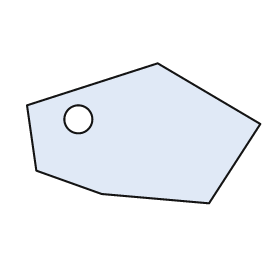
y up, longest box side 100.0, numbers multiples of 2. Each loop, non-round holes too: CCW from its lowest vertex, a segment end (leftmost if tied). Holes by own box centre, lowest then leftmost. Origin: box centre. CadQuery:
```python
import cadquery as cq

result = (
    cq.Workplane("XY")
    .moveTo(28.0, -30.0)
    .lineTo(50.0, 4.0)
    .lineTo(6.0, 30.0)
    .lineTo(-50.0, 12.0)
    .lineTo(-46.0, -16.0)
    .lineTo(-18.0, -26.0)
    .close()
    .moveTo(-28.0, 6.0)
    .circle(6.0)
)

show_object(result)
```